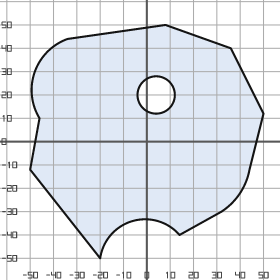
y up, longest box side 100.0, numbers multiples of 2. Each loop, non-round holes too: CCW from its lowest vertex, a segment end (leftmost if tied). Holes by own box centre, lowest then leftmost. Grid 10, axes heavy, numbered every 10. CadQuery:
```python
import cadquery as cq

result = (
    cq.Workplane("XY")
    .moveTo(-20.0, -50.0)
    .threePointArc((-6.0, -34.0), (14.0, -40.0))
    .lineTo(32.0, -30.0)
    .threePointArc((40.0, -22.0), (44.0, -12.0))
    .lineTo(50.0, 12.0)
    .lineTo(36.0, 40.0)
    .lineTo(8.0, 50.0)
    .lineTo(-34.0, 44.0)
    .threePointArc((-48.0, 30.0), (-46.0, 10.0))
    .lineTo(-50.0, -12.0)
    .close()
    .moveTo(4.0, 20.0)
    .circle(8.0)
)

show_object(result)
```